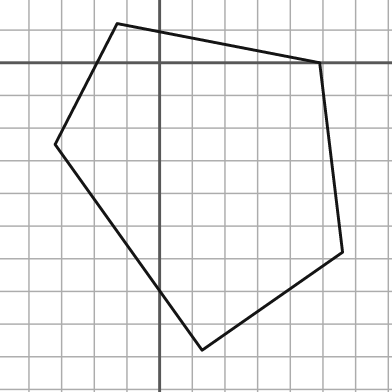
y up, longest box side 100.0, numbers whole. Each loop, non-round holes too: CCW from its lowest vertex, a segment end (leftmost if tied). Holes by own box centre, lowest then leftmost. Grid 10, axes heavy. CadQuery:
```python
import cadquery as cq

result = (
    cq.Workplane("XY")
    .moveTo(13.0, -88.0)
    .lineTo(56.0, -58.0)
    .lineTo(49.0, 0.0)
    .lineTo(-13.0, 12.0)
    .lineTo(-32.0, -25.0)
    .close()
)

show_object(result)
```